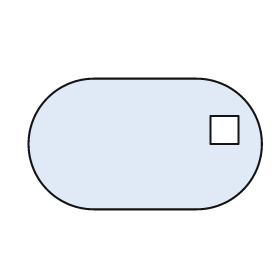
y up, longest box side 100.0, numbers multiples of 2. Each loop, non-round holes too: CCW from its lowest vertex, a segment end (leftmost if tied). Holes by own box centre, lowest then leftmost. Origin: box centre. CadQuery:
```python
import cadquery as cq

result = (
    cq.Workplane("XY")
    .moveTo(-22.0, -28.0)
    .lineTo(22.0, -28.0)
    .threePointArc((50.0, 0.0), (22.0, 28.0))
    .lineTo(-22.0, 28.0)
    .threePointArc((-50.0, 0.0), (-22.0, -28.0))
    .close()
    .moveTo(28.0, 0.0)
    .lineTo(40.0, 0.0)
    .lineTo(40.0, 12.0)
    .lineTo(28.0, 12.0)
    .close()
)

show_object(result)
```